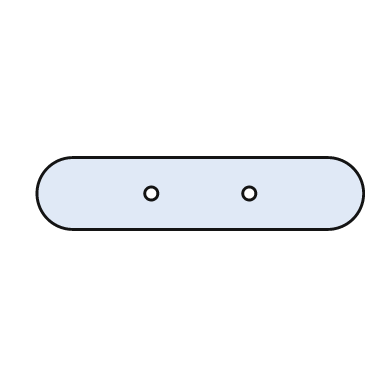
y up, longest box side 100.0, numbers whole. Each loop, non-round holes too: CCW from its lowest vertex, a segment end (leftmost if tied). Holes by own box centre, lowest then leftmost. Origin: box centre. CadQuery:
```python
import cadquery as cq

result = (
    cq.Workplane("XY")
    .moveTo(-39.0, -11.0)
    .lineTo(39.0, -11.0)
    .threePointArc((50.0, 0.0), (39.0, 11.0))
    .lineTo(-39.0, 11.0)
    .threePointArc((-50.0, 0.0), (-39.0, -11.0))
    .close()
    .moveTo(-15.0, 0.0)
    .circle(2.0)
    .moveTo(15.0, 0.0)
    .circle(2.0)
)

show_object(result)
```